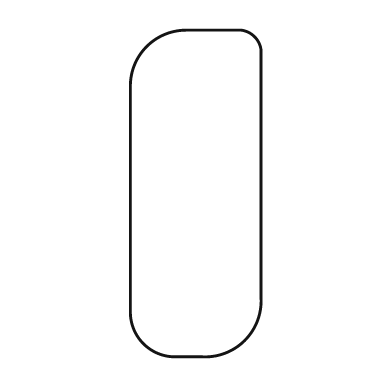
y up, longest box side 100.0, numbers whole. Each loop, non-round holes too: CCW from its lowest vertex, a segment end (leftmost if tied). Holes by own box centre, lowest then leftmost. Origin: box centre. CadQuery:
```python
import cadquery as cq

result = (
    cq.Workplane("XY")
    .moveTo(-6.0, -50.0)
    .lineTo(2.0, -50.0)
    .threePointArc((15.0, -45.0), (20.0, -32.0))
    .lineTo(20.0, 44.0)
    .threePointArc((18.0, 48.0), (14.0, 50.0))
    .lineTo(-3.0, 50.0)
    .threePointArc((-15.0, 45.0), (-20.0, 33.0))
    .lineTo(-20.0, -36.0)
    .threePointArc((-16.0, -46.0), (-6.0, -50.0))
    .close()
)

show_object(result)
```